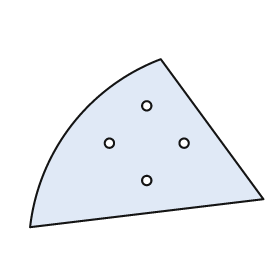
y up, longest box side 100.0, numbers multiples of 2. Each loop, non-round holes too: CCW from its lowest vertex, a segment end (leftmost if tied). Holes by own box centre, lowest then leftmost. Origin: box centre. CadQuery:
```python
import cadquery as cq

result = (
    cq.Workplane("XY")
    .moveTo(-50.0, -36.0)
    .lineTo(50.0, -24.0)
    .lineTo(6.0, 36.0)
    .threePointArc((-32.0, 8.0), (-50.0, -36.0))
    .close()
    .moveTo(0.0, -16.0)
    .circle(2.0)
    .moveTo(-16.0, 0.0)
    .circle(2.0)
    .moveTo(16.0, 0.0)
    .circle(2.0)
    .moveTo(0.0, 16.0)
    .circle(2.0)
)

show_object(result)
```